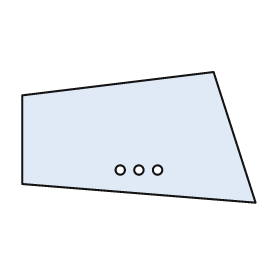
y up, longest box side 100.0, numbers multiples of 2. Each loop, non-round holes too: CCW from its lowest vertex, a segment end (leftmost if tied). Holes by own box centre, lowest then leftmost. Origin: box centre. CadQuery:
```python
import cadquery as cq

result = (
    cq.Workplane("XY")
    .moveTo(50.0, -28.0)
    .lineTo(32.0, 28.0)
    .lineTo(-50.0, 18.0)
    .lineTo(-50.0, -20.0)
    .close()
    .moveTo(-8.0, -14.0)
    .circle(2.0)
    .moveTo(0.0, -14.0)
    .circle(2.0)
    .moveTo(8.0, -14.0)
    .circle(2.0)
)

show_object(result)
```